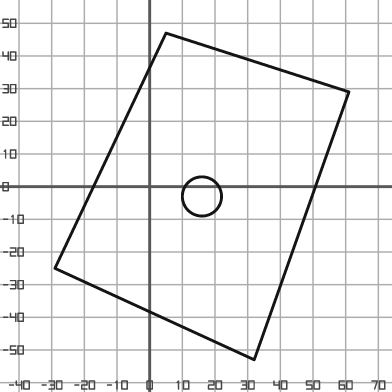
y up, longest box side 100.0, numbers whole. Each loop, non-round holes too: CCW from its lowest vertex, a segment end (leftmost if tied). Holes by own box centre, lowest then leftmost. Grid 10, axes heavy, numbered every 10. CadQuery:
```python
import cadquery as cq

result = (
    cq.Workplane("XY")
    .moveTo(32.0, -53.0)
    .lineTo(61.0, 29.0)
    .lineTo(5.0, 47.0)
    .lineTo(-29.0, -25.0)
    .close()
    .moveTo(16.0, -3.0)
    .circle(6.0)
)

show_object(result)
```